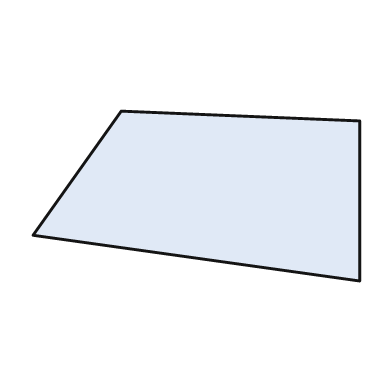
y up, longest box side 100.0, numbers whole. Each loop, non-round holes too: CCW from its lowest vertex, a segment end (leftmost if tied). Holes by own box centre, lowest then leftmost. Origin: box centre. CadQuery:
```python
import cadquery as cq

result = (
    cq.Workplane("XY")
    .moveTo(50.0, -26.0)
    .lineTo(50.0, 23.0)
    .lineTo(-23.0, 26.0)
    .lineTo(-50.0, -12.0)
    .close()
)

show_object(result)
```